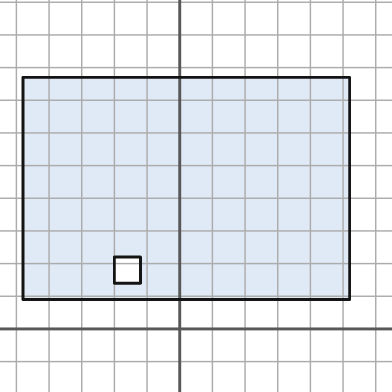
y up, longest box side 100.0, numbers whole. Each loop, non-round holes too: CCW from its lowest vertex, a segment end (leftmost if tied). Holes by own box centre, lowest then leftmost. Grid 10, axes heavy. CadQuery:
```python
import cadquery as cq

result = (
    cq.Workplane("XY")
    .moveTo(-48.0, 9.0)
    .lineTo(52.0, 9.0)
    .lineTo(52.0, 77.0)
    .lineTo(-48.0, 77.0)
    .close()
    .moveTo(-20.0, 14.0)
    .lineTo(-12.0, 14.0)
    .lineTo(-12.0, 22.0)
    .lineTo(-20.0, 22.0)
    .close()
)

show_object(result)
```